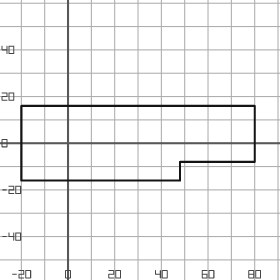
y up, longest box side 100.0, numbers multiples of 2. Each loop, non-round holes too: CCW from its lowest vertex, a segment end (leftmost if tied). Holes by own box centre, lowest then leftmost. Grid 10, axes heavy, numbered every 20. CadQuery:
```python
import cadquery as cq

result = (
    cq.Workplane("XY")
    .moveTo(-20.0, -16.0)
    .lineTo(48.0, -16.0)
    .lineTo(48.0, -8.0)
    .lineTo(80.0, -8.0)
    .lineTo(80.0, 16.0)
    .lineTo(-20.0, 16.0)
    .close()
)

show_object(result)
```